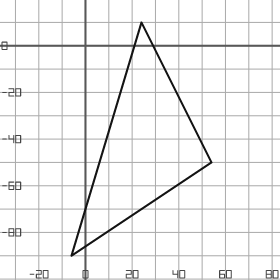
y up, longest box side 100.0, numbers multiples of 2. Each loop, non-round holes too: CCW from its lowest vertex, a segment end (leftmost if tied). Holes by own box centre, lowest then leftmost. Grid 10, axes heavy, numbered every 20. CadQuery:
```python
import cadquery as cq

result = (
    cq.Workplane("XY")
    .moveTo(-6.0, -90.0)
    .lineTo(54.0, -50.0)
    .lineTo(24.0, 10.0)
    .close()
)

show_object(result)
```